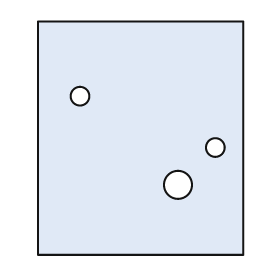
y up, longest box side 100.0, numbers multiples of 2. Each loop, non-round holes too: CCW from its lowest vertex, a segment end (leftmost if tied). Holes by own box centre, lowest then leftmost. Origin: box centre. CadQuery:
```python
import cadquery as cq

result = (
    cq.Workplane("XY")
    .moveTo(-44.0, -50.0)
    .lineTo(44.0, -50.0)
    .lineTo(44.0, 50.0)
    .lineTo(-44.0, 50.0)
    .close()
    .moveTo(16.0, -20.0)
    .circle(6.0)
    .moveTo(32.0, -4.0)
    .circle(4.0)
    .moveTo(-26.0, 18.0)
    .circle(4.0)
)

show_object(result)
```